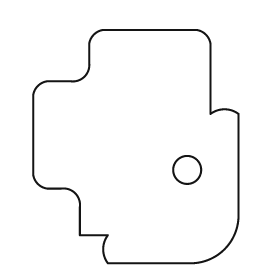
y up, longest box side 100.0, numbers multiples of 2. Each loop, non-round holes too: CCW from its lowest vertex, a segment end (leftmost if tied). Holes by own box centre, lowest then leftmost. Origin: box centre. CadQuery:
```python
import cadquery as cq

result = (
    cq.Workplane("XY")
    .moveTo(-12.0, -50.0)
    .lineTo(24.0, -50.0)
    .threePointArc((38.0, -44.0), (44.0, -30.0))
    .lineTo(44.0, 14.0)
    .threePointArc((38.0, 16.0), (32.0, 14.0))
    .lineTo(32.0, 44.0)
    .threePointArc((30.0, 48.0), (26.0, 50.0))
    .lineTo(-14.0, 50.0)
    .threePointArc((-18.0, 48.0), (-20.0, 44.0))
    .lineTo(-20.0, 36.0)
    .threePointArc((-22.0, 30.0), (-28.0, 28.0))
    .lineTo(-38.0, 28.0)
    .threePointArc((-42.0, 26.0), (-44.0, 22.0))
    .lineTo(-44.0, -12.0)
    .threePointArc((-42.0, -16.0), (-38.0, -18.0))
    .lineTo(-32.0, -18.0)
    .threePointArc((-26.0, -20.0), (-24.0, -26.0))
    .lineTo(-24.0, -38.0)
    .lineTo(-12.0, -38.0)
    .threePointArc((-14.0, -44.0), (-12.0, -50.0))
    .close()
    .moveTo(22.0, -10.0)
    .circle(6.0)
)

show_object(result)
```